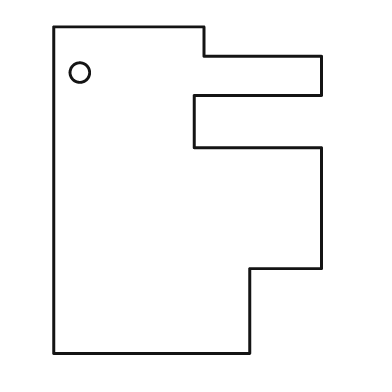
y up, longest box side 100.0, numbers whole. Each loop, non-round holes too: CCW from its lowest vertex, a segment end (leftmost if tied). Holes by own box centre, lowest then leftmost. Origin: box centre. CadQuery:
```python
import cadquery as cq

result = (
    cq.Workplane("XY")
    .moveTo(-41.0, -50.0)
    .lineTo(19.0, -50.0)
    .lineTo(19.0, -24.0)
    .lineTo(41.0, -24.0)
    .lineTo(41.0, 13.0)
    .lineTo(2.0, 13.0)
    .lineTo(2.0, 29.0)
    .lineTo(41.0, 29.0)
    .lineTo(41.0, 41.0)
    .lineTo(5.0, 41.0)
    .lineTo(5.0, 50.0)
    .lineTo(-41.0, 50.0)
    .close()
    .moveTo(-33.0, 36.0)
    .circle(3.0)
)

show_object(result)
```